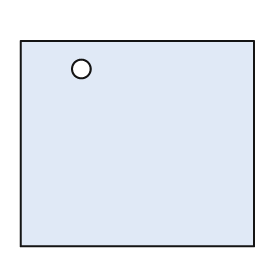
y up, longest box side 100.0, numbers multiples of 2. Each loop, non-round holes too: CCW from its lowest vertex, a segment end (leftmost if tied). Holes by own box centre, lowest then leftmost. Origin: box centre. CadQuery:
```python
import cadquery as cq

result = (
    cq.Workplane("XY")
    .moveTo(-50.0, -44.0)
    .lineTo(50.0, -44.0)
    .lineTo(50.0, 44.0)
    .lineTo(-50.0, 44.0)
    .close()
    .moveTo(-24.0, 32.0)
    .circle(4.0)
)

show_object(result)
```